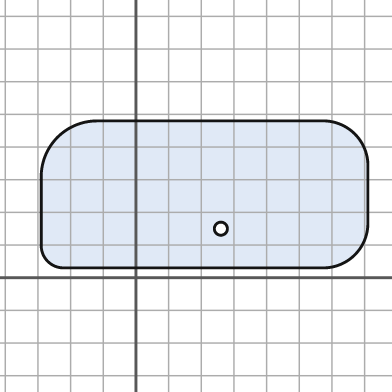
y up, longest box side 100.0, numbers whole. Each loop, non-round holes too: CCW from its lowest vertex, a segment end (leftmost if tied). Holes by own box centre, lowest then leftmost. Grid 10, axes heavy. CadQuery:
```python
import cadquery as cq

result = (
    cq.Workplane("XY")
    .moveTo(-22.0, 3.0)
    .lineTo(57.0, 3.0)
    .threePointArc((67.0, 7.0), (71.0, 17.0))
    .lineTo(71.0, 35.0)
    .threePointArc((67.0, 44.0), (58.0, 48.0))
    .lineTo(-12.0, 48.0)
    .threePointArc((-24.0, 43.0), (-29.0, 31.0))
    .lineTo(-29.0, 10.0)
    .threePointArc((-27.0, 5.0), (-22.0, 3.0))
    .close()
    .moveTo(26.0, 15.0)
    .circle(2.0)
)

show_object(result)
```